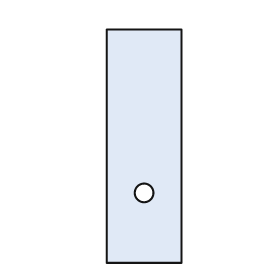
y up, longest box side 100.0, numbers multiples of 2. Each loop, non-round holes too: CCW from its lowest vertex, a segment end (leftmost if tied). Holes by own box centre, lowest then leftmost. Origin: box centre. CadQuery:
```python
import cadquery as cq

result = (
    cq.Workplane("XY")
    .moveTo(-16.0, -50.0)
    .lineTo(16.0, -50.0)
    .lineTo(16.0, 50.0)
    .lineTo(-16.0, 50.0)
    .close()
    .moveTo(0.0, -20.0)
    .circle(4.0)
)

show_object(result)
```